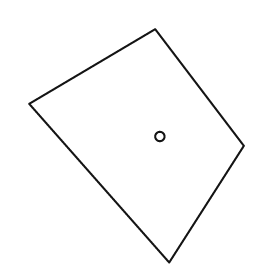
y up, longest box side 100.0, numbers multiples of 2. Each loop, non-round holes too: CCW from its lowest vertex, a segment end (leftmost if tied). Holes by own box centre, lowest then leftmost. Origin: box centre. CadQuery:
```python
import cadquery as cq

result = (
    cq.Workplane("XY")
    .moveTo(14.0, -50.0)
    .lineTo(46.0, 0.0)
    .lineTo(8.0, 50.0)
    .lineTo(-46.0, 18.0)
    .close()
    .moveTo(10.0, 4.0)
    .circle(2.0)
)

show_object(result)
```